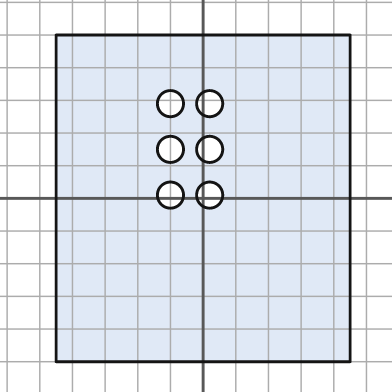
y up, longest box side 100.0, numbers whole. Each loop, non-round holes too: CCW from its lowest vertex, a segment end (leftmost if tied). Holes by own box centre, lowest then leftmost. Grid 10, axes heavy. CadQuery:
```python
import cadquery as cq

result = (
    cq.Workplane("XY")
    .moveTo(-45.0, -50.0)
    .lineTo(45.0, -50.0)
    .lineTo(45.0, 50.0)
    .lineTo(-45.0, 50.0)
    .close()
    .moveTo(-10.0, 1.0)
    .circle(4.0)
    .moveTo(2.0, 1.0)
    .circle(4.0)
    .moveTo(-10.0, 15.0)
    .circle(4.0)
    .moveTo(2.0, 15.0)
    .circle(4.0)
    .moveTo(-10.0, 29.0)
    .circle(4.0)
    .moveTo(2.0, 29.0)
    .circle(4.0)
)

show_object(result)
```